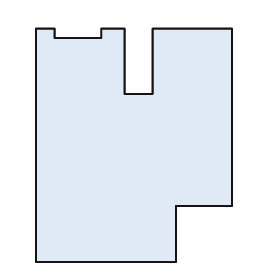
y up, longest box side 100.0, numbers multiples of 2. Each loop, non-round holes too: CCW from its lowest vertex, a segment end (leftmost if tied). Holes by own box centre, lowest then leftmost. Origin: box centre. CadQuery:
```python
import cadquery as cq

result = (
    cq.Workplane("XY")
    .moveTo(-42.0, -50.0)
    .lineTo(18.0, -50.0)
    .lineTo(18.0, -26.0)
    .lineTo(42.0, -26.0)
    .lineTo(42.0, 50.0)
    .lineTo(8.0, 50.0)
    .lineTo(8.0, 22.0)
    .lineTo(-4.0, 22.0)
    .lineTo(-4.0, 50.0)
    .lineTo(-14.0, 50.0)
    .lineTo(-14.0, 46.0)
    .lineTo(-34.0, 46.0)
    .lineTo(-34.0, 50.0)
    .lineTo(-42.0, 50.0)
    .close()
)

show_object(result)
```